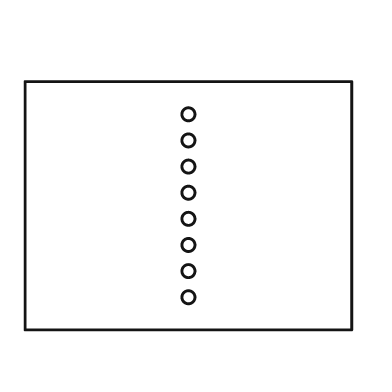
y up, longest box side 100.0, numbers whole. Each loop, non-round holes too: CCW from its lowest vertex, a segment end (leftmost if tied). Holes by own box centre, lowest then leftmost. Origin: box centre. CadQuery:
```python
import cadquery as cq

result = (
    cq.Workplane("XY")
    .moveTo(-50.0, -38.0)
    .lineTo(50.0, -38.0)
    .lineTo(50.0, 38.0)
    .lineTo(-50.0, 38.0)
    .close()
    .moveTo(0.0, -28.0)
    .circle(2.0)
    .moveTo(0.0, -20.0)
    .circle(2.0)
    .moveTo(0.0, -12.0)
    .circle(2.0)
    .moveTo(0.0, -4.0)
    .circle(2.0)
    .moveTo(0.0, 4.0)
    .circle(2.0)
    .moveTo(0.0, 12.0)
    .circle(2.0)
    .moveTo(0.0, 20.0)
    .circle(2.0)
    .moveTo(0.0, 28.0)
    .circle(2.0)
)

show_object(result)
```